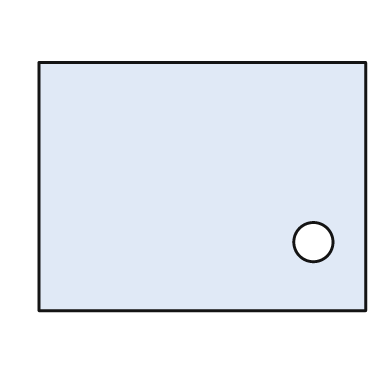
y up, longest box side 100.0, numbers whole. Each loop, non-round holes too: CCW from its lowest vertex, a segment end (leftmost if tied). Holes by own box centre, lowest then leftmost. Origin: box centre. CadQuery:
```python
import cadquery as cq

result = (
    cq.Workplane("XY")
    .moveTo(-50.0, -38.0)
    .lineTo(50.0, -38.0)
    .lineTo(50.0, 38.0)
    .lineTo(-50.0, 38.0)
    .close()
    .moveTo(34.0, -17.0)
    .circle(6.0)
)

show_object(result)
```